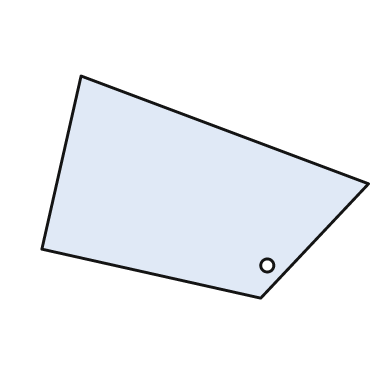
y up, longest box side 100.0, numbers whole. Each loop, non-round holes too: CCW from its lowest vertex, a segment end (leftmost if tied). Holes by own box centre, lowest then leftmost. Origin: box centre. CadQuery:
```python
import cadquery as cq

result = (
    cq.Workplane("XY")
    .moveTo(17.0, -34.0)
    .lineTo(50.0, 1.0)
    .lineTo(-38.0, 34.0)
    .lineTo(-50.0, -19.0)
    .close()
    .moveTo(19.0, -24.0)
    .circle(2.0)
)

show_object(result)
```